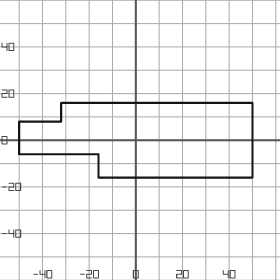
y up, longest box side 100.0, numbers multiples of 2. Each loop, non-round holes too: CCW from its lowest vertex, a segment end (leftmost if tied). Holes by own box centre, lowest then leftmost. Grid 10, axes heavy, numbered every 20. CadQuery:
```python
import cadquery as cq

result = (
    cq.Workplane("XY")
    .moveTo(-16.0, -16.0)
    .lineTo(50.0, -16.0)
    .lineTo(50.0, 16.0)
    .lineTo(-32.0, 16.0)
    .lineTo(-32.0, 8.0)
    .lineTo(-50.0, 8.0)
    .lineTo(-50.0, -6.0)
    .lineTo(-16.0, -6.0)
    .close()
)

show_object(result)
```